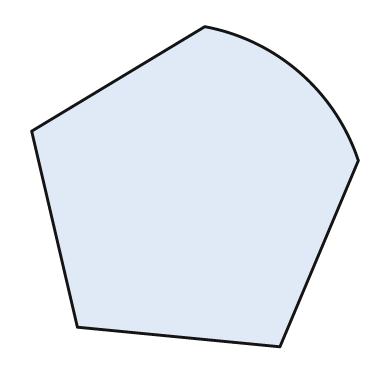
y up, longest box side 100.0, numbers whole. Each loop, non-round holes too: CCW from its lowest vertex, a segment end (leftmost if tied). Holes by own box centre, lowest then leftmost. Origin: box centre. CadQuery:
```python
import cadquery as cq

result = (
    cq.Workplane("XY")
    .moveTo(26.0, -49.0)
    .lineTo(50.0, 8.0)
    .threePointArc((32.0, 35.0), (3.0, 49.0))
    .lineTo(-50.0, 17.0)
    .lineTo(-36.0, -43.0)
    .close()
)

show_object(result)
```